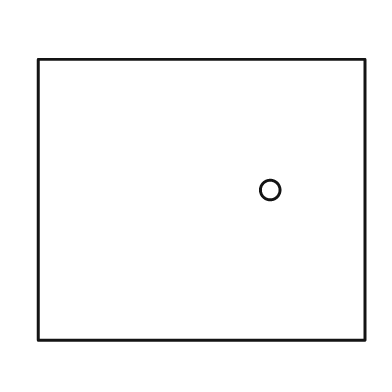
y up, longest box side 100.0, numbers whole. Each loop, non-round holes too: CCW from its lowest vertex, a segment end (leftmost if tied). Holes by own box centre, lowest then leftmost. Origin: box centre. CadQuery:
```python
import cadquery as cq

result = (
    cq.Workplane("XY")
    .moveTo(-50.0, -43.0)
    .lineTo(50.0, -43.0)
    .lineTo(50.0, 43.0)
    .lineTo(-50.0, 43.0)
    .close()
    .moveTo(21.0, 3.0)
    .circle(3.0)
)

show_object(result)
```